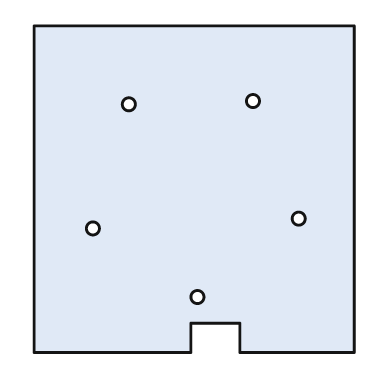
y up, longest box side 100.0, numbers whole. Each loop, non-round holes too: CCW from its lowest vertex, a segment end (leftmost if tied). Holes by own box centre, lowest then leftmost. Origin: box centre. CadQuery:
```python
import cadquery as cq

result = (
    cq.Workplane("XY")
    .moveTo(-49.0, -50.0)
    .lineTo(-1.0, -50.0)
    .lineTo(-1.0, -41.0)
    .lineTo(14.0, -41.0)
    .lineTo(14.0, -50.0)
    .lineTo(49.0, -50.0)
    .lineTo(49.0, 50.0)
    .lineTo(-49.0, 50.0)
    .close()
    .moveTo(1.0, -33.0)
    .circle(2.0)
    .moveTo(-31.0, -12.0)
    .circle(2.0)
    .moveTo(32.0, -9.0)
    .circle(2.0)
    .moveTo(-20.0, 26.0)
    .circle(2.0)
    .moveTo(18.0, 27.0)
    .circle(2.0)
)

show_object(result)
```